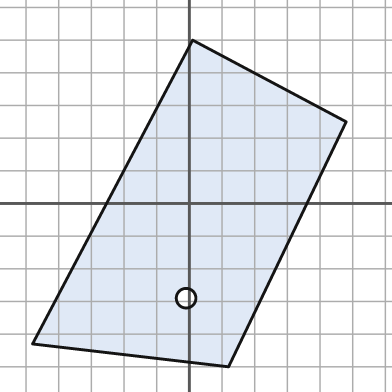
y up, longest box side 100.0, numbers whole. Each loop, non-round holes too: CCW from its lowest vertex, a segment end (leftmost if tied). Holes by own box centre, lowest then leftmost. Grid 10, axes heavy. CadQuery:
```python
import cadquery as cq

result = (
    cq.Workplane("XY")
    .moveTo(12.0, -50.0)
    .lineTo(48.0, 25.0)
    .lineTo(1.0, 50.0)
    .lineTo(-48.0, -43.0)
    .close()
    .moveTo(-1.0, -29.0)
    .circle(3.0)
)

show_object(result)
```